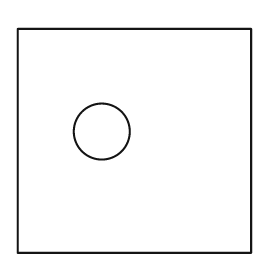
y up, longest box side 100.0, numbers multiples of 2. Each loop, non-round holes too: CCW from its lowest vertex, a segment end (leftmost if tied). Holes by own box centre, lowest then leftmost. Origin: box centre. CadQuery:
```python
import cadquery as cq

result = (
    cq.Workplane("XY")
    .moveTo(-50.0, -48.0)
    .lineTo(50.0, -48.0)
    .lineTo(50.0, 48.0)
    .lineTo(-50.0, 48.0)
    .close()
    .moveTo(-14.0, 4.0)
    .circle(12.0)
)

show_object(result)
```